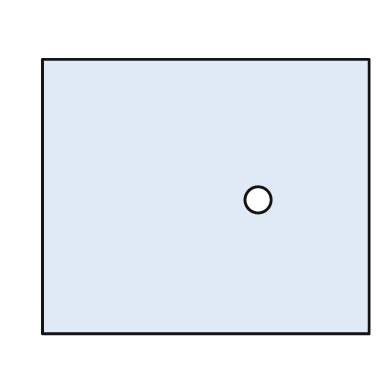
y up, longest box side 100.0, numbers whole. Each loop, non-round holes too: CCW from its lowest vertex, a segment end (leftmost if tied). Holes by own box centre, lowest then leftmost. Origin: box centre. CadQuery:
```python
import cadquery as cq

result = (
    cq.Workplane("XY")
    .moveTo(-50.0, -42.0)
    .lineTo(50.0, -42.0)
    .lineTo(50.0, 42.0)
    .lineTo(-50.0, 42.0)
    .close()
    .moveTo(16.0, -1.0)
    .circle(4.0)
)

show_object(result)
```